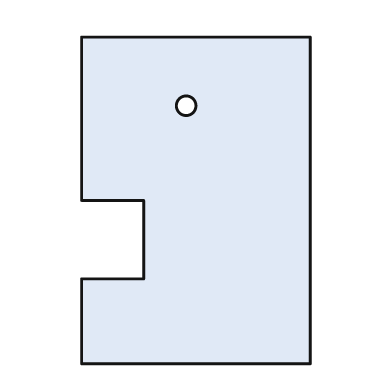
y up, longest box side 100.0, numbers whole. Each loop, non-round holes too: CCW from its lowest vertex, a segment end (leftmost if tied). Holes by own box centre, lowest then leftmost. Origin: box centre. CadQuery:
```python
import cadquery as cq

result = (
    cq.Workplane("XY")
    .moveTo(-35.0, -50.0)
    .lineTo(35.0, -50.0)
    .lineTo(35.0, 50.0)
    .lineTo(-35.0, 50.0)
    .lineTo(-35.0, 0.0)
    .lineTo(-16.0, 0.0)
    .lineTo(-16.0, -24.0)
    .lineTo(-35.0, -24.0)
    .close()
    .moveTo(-3.0, 29.0)
    .circle(3.0)
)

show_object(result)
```